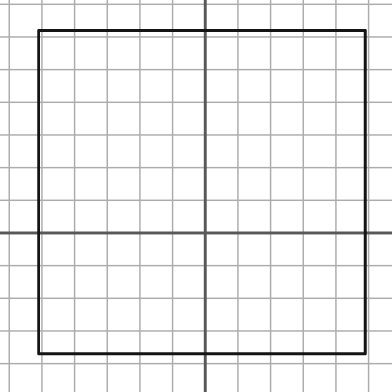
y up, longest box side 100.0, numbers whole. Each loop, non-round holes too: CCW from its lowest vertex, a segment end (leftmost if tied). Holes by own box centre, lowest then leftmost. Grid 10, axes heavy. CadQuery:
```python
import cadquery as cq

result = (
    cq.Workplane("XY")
    .moveTo(-51.0, -37.0)
    .lineTo(49.0, -37.0)
    .lineTo(49.0, 62.0)
    .lineTo(-51.0, 62.0)
    .close()
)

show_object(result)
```